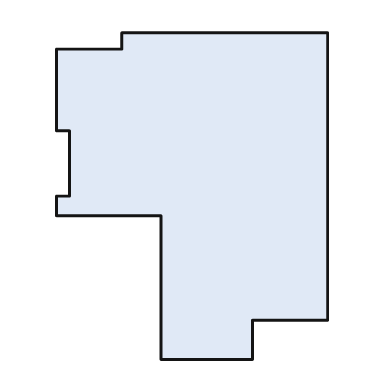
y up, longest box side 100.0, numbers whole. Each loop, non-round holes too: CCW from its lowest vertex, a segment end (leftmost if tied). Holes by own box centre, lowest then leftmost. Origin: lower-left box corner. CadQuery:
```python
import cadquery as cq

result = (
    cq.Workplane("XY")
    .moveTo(32.0, 0.0)
    .lineTo(60.0, 0.0)
    .lineTo(60.0, 12.0)
    .lineTo(83.0, 12.0)
    .lineTo(83.0, 100.0)
    .lineTo(20.0, 100.0)
    .lineTo(20.0, 95.0)
    .lineTo(0.0, 95.0)
    .lineTo(0.0, 70.0)
    .lineTo(4.0, 70.0)
    .lineTo(4.0, 50.0)
    .lineTo(0.0, 50.0)
    .lineTo(0.0, 44.0)
    .lineTo(32.0, 44.0)
    .close()
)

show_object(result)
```